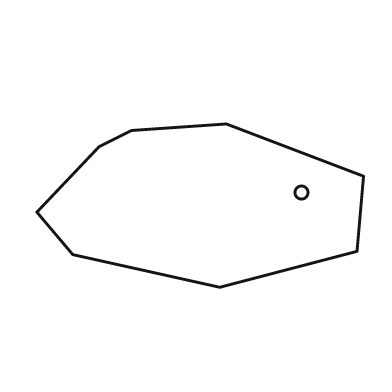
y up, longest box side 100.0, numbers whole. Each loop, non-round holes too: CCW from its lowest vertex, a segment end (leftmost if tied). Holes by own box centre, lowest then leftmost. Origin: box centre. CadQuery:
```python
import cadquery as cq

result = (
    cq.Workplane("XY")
    .moveTo(6.0, -25.0)
    .lineTo(48.0, -14.0)
    .lineTo(50.0, 9.0)
    .lineTo(8.0, 25.0)
    .lineTo(-21.0, 23.0)
    .lineTo(-31.0, 18.0)
    .lineTo(-50.0, -2.0)
    .lineTo(-39.0, -15.0)
    .close()
    .moveTo(31.0, 4.0)
    .circle(2.0)
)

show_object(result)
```